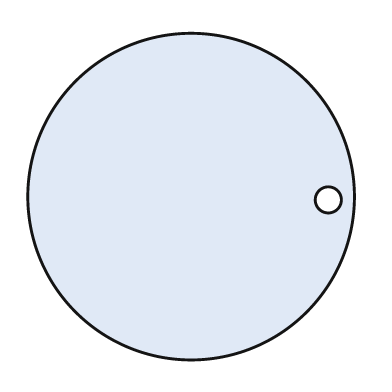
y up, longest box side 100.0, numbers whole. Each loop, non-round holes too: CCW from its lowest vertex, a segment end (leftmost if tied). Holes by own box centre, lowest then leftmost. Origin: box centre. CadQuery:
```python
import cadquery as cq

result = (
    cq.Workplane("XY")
    .moveTo(0.0, 0.0)
    .circle(50.0)
    .moveTo(42.0, -1.0)
    .circle(4.0)
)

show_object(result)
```